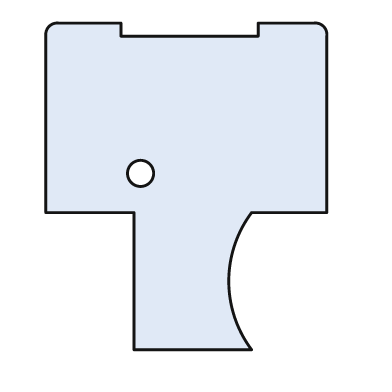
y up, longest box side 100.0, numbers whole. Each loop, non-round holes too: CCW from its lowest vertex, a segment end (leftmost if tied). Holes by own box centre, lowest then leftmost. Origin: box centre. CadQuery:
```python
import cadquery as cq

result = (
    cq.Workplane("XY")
    .moveTo(-16.0, -50.0)
    .lineTo(20.0, -50.0)
    .threePointArc((13.0, -29.0), (20.0, -8.0))
    .lineTo(43.0, -8.0)
    .lineTo(43.0, 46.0)
    .threePointArc((42.0, 49.0), (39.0, 50.0))
    .lineTo(22.0, 50.0)
    .lineTo(22.0, 46.0)
    .lineTo(-20.0, 46.0)
    .lineTo(-20.0, 50.0)
    .lineTo(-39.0, 50.0)
    .threePointArc((-42.0, 49.0), (-43.0, 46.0))
    .lineTo(-43.0, -8.0)
    .lineTo(-16.0, -8.0)
    .close()
    .moveTo(-14.0, 4.0)
    .circle(4.0)
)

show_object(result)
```